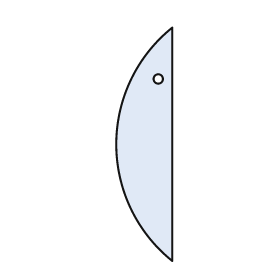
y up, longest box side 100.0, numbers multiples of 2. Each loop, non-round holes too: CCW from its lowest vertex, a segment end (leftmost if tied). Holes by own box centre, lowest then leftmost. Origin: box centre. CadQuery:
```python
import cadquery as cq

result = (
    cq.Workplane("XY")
    .moveTo(12.0, -50.0)
    .lineTo(12.0, 50.0)
    .threePointArc((-12.0, 0.0), (12.0, -50.0))
    .close()
    .moveTo(6.0, 28.0)
    .circle(2.0)
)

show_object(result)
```